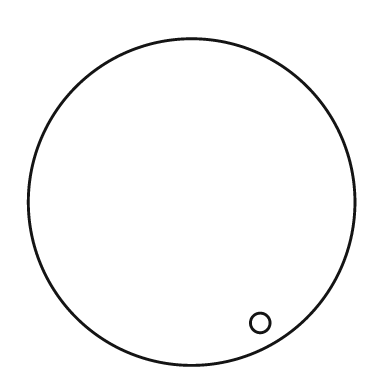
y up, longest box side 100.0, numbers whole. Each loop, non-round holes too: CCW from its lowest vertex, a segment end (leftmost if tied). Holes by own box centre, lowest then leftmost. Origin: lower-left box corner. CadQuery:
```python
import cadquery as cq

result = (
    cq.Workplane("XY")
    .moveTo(50.0, 50.0)
    .circle(50.0)
    .moveTo(71.0, 13.0)
    .circle(3.0)
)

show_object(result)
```